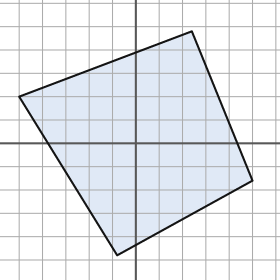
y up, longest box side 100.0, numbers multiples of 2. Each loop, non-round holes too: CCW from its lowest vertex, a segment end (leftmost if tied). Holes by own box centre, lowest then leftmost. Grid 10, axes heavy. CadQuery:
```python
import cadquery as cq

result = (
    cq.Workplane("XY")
    .moveTo(-8.0, -48.0)
    .lineTo(50.0, -16.0)
    .lineTo(24.0, 48.0)
    .lineTo(-50.0, 20.0)
    .close()
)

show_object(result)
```